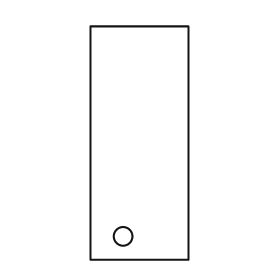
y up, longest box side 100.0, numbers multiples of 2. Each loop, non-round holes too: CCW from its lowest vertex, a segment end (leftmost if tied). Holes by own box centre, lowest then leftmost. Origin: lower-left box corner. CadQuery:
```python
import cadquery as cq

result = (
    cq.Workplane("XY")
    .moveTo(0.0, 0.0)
    .lineTo(42.0, 0.0)
    .lineTo(42.0, 100.0)
    .lineTo(0.0, 100.0)
    .close()
    .moveTo(14.0, 10.0)
    .circle(4.0)
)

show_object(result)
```